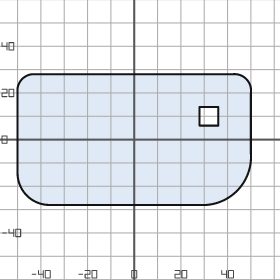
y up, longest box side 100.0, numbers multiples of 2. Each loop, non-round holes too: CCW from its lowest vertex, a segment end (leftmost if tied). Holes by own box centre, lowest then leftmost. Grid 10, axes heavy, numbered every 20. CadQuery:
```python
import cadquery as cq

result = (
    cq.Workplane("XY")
    .moveTo(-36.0, -28.0)
    .lineTo(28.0, -28.0)
    .threePointArc((44.0, -22.0), (50.0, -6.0))
    .lineTo(50.0, 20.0)
    .threePointArc((48.0, 26.0), (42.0, 28.0))
    .lineTo(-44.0, 28.0)
    .threePointArc((-48.0, 26.0), (-50.0, 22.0))
    .lineTo(-50.0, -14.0)
    .threePointArc((-46.0, -24.0), (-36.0, -28.0))
    .close()
    .moveTo(28.0, 6.0)
    .lineTo(36.0, 6.0)
    .lineTo(36.0, 14.0)
    .lineTo(28.0, 14.0)
    .close()
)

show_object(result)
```